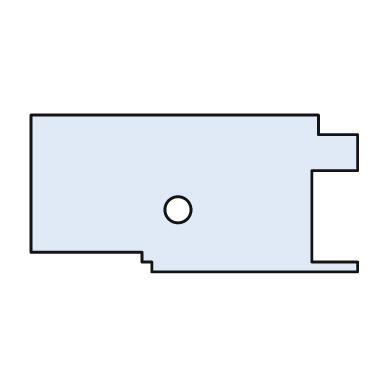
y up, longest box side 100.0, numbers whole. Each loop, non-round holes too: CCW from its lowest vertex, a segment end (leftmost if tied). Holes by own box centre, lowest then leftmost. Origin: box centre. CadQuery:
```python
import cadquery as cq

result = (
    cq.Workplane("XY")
    .moveTo(-13.0, -24.0)
    .lineTo(50.0, -24.0)
    .lineTo(50.0, -21.0)
    .lineTo(36.0, -21.0)
    .lineTo(36.0, 7.0)
    .lineTo(50.0, 7.0)
    .lineTo(50.0, 18.0)
    .lineTo(38.0, 18.0)
    .lineTo(38.0, 24.0)
    .lineTo(-50.0, 24.0)
    .lineTo(-50.0, -18.0)
    .lineTo(-16.0, -18.0)
    .lineTo(-16.0, -21.0)
    .lineTo(-13.0, -21.0)
    .close()
    .moveTo(-5.0, -5.0)
    .circle(4.0)
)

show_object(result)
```